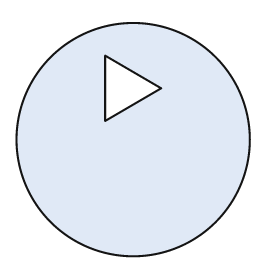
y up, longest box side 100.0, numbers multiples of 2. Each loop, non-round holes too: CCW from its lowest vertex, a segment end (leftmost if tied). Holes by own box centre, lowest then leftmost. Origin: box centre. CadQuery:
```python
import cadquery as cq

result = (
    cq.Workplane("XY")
    .moveTo(0.0, 0.0)
    .circle(50.0)
    .moveTo(-12.0, 8.0)
    .lineTo(12.0, 22.0)
    .lineTo(-12.0, 36.0)
    .close()
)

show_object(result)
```